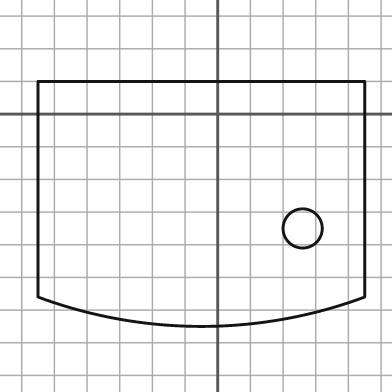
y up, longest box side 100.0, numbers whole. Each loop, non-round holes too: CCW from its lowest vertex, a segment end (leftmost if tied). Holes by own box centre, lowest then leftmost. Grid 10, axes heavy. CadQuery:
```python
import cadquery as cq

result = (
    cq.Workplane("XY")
    .moveTo(-55.0, -56.0)
    .threePointArc((-5.0, -65.0), (45.0, -56.0))
    .lineTo(45.0, 10.0)
    .lineTo(-55.0, 10.0)
    .close()
    .moveTo(26.0, -35.0)
    .circle(6.0)
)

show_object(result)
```